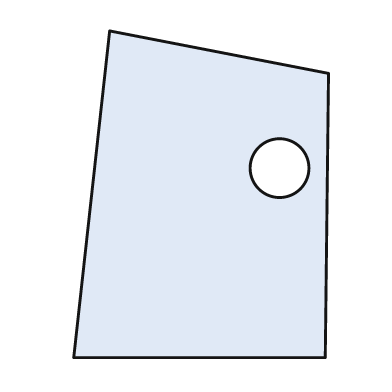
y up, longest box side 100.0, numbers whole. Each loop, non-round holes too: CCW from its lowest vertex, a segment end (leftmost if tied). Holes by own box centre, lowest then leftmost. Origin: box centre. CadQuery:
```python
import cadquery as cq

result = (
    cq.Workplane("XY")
    .moveTo(-39.0, -50.0)
    .lineTo(38.0, -50.0)
    .lineTo(39.0, 37.0)
    .lineTo(-28.0, 50.0)
    .close()
    .moveTo(24.0, 8.0)
    .circle(9.0)
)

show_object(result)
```